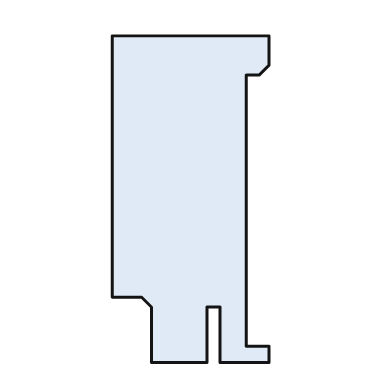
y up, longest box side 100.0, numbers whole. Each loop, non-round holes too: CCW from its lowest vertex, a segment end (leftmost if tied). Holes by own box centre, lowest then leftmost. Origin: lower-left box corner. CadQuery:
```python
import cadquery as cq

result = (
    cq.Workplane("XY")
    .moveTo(12.0, 0.0)
    .lineTo(29.0, 0.0)
    .lineTo(29.0, 17.0)
    .lineTo(33.0, 17.0)
    .lineTo(33.0, 0.0)
    .lineTo(48.0, 0.0)
    .lineTo(48.0, 5.0)
    .lineTo(41.0, 5.0)
    .lineTo(41.0, 88.0)
    .lineTo(45.0, 88.0)
    .lineTo(48.0, 91.0)
    .lineTo(48.0, 100.0)
    .lineTo(0.0, 100.0)
    .lineTo(0.0, 20.0)
    .lineTo(9.0, 20.0)
    .lineTo(12.0, 17.0)
    .close()
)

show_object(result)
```